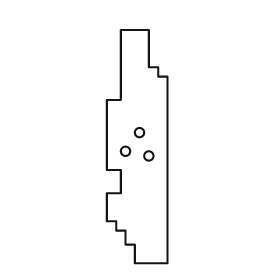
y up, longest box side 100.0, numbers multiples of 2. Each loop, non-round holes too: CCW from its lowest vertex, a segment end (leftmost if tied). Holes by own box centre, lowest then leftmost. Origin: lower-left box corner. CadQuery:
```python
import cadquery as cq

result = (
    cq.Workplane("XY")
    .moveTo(12.0, 0.0)
    .lineTo(26.0, 0.0)
    .lineTo(26.0, 80.0)
    .lineTo(22.0, 80.0)
    .lineTo(22.0, 84.0)
    .lineTo(18.0, 84.0)
    .lineTo(18.0, 100.0)
    .lineTo(6.0, 100.0)
    .lineTo(6.0, 70.0)
    .lineTo(0.0, 70.0)
    .lineTo(0.0, 40.0)
    .lineTo(6.0, 40.0)
    .lineTo(6.0, 30.0)
    .lineTo(0.0, 30.0)
    .lineTo(0.0, 18.0)
    .lineTo(4.0, 18.0)
    .lineTo(4.0, 14.0)
    .lineTo(8.0, 14.0)
    .lineTo(8.0, 8.0)
    .lineTo(12.0, 8.0)
    .close()
    .moveTo(18.0, 46.0)
    .circle(2.0)
    .moveTo(8.0, 48.0)
    .circle(2.0)
    .moveTo(14.0, 56.0)
    .circle(2.0)
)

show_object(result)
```